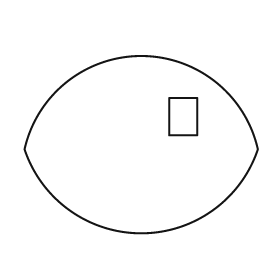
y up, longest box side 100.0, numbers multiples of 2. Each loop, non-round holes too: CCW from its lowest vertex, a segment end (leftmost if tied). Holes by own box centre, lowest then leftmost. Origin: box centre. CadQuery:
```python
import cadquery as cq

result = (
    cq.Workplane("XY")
    .moveTo(-50.0, -2.0)
    .threePointArc((0.0, -38.0), (50.0, -2.0))
    .threePointArc((0.0, 38.0), (-50.0, -2.0))
    .close()
    .moveTo(12.0, 4.0)
    .lineTo(24.0, 4.0)
    .lineTo(24.0, 20.0)
    .lineTo(12.0, 20.0)
    .close()
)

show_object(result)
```